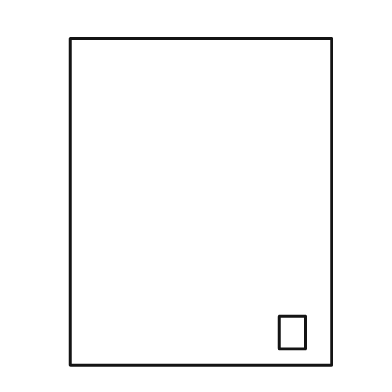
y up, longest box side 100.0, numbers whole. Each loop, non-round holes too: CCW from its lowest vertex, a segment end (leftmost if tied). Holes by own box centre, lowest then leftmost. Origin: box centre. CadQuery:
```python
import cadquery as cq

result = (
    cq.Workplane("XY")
    .moveTo(-40.0, -50.0)
    .lineTo(40.0, -50.0)
    .lineTo(40.0, 50.0)
    .lineTo(-40.0, 50.0)
    .close()
    .moveTo(24.0, -45.0)
    .lineTo(32.0, -45.0)
    .lineTo(32.0, -35.0)
    .lineTo(24.0, -35.0)
    .close()
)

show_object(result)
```